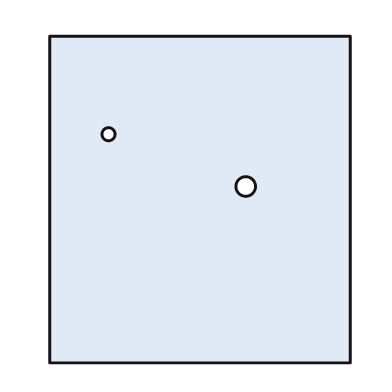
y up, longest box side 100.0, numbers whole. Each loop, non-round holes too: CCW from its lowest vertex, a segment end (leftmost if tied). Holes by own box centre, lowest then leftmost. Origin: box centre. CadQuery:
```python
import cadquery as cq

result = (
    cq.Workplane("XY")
    .moveTo(-46.0, -50.0)
    .lineTo(46.0, -50.0)
    .lineTo(46.0, 50.0)
    .lineTo(-46.0, 50.0)
    .close()
    .moveTo(14.0, 4.0)
    .circle(3.0)
    .moveTo(-28.0, 20.0)
    .circle(2.0)
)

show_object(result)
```